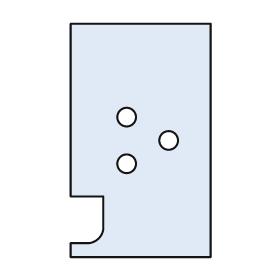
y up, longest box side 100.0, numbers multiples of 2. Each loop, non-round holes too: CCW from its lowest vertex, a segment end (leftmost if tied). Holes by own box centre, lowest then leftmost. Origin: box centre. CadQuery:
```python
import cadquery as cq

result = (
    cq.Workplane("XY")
    .moveTo(-30.0, -50.0)
    .lineTo(30.0, -50.0)
    .lineTo(30.0, 50.0)
    .lineTo(-30.0, 50.0)
    .lineTo(-30.0, -24.0)
    .lineTo(-16.0, -24.0)
    .lineTo(-16.0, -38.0)
    .threePointArc((-18.0, -42.0), (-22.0, -44.0))
    .lineTo(-30.0, -44.0)
    .close()
    .moveTo(-6.0, -10.0)
    .circle(4.0)
    .moveTo(12.0, 0.0)
    .circle(4.0)
    .moveTo(-6.0, 10.0)
    .circle(4.0)
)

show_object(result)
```